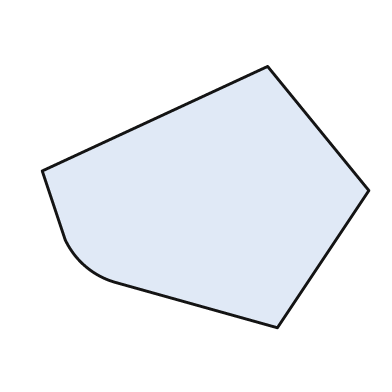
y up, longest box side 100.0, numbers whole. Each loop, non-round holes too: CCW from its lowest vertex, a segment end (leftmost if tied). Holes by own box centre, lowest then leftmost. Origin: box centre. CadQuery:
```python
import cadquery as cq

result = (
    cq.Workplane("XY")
    .moveTo(22.0, -40.0)
    .lineTo(50.0, 2.0)
    .lineTo(19.0, 40.0)
    .lineTo(-50.0, 8.0)
    .lineTo(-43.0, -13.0)
    .threePointArc((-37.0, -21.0), (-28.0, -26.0))
    .close()
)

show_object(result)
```